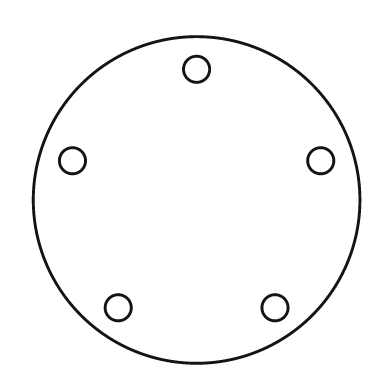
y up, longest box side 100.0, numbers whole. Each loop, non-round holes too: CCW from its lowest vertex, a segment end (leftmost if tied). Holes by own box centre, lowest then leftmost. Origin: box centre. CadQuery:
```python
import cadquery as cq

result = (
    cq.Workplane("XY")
    .moveTo(0.0, 0.0)
    .circle(50.0)
    .moveTo(-24.0, -33.0)
    .circle(4.0)
    .moveTo(24.0, -33.0)
    .circle(4.0)
    .moveTo(-38.0, 12.0)
    .circle(4.0)
    .moveTo(38.0, 12.0)
    .circle(4.0)
    .moveTo(0.0, 40.0)
    .circle(4.0)
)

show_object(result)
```